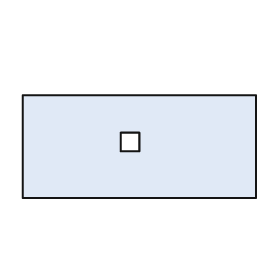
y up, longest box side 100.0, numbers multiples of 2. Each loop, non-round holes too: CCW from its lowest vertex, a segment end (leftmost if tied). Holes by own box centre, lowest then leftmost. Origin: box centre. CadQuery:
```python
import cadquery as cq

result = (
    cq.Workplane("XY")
    .moveTo(-50.0, -22.0)
    .lineTo(50.0, -22.0)
    .lineTo(50.0, 22.0)
    .lineTo(-50.0, 22.0)
    .close()
    .moveTo(-8.0, -2.0)
    .lineTo(0.0, -2.0)
    .lineTo(0.0, 6.0)
    .lineTo(-8.0, 6.0)
    .close()
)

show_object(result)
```